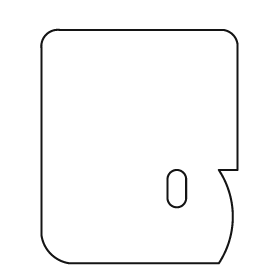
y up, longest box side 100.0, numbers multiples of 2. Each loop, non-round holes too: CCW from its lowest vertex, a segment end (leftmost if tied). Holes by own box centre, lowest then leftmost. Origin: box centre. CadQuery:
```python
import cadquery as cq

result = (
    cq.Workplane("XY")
    .moveTo(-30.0, -50.0)
    .lineTo(34.0, -50.0)
    .threePointArc((40.0, -30.0), (34.0, -10.0))
    .lineTo(42.0, -10.0)
    .lineTo(42.0, 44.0)
    .threePointArc((40.0, 48.0), (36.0, 50.0))
    .lineTo(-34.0, 50.0)
    .threePointArc((-40.0, 48.0), (-42.0, 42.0))
    .lineTo(-42.0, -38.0)
    .threePointArc((-38.0, -46.0), (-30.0, -50.0))
    .close()
    .moveTo(12.0, -22.0)
    .threePointArc((16.0, -26.0), (20.0, -22.0))
    .lineTo(20.0, -14.0)
    .threePointArc((16.0, -10.0), (12.0, -14.0))
    .close()
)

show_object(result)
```